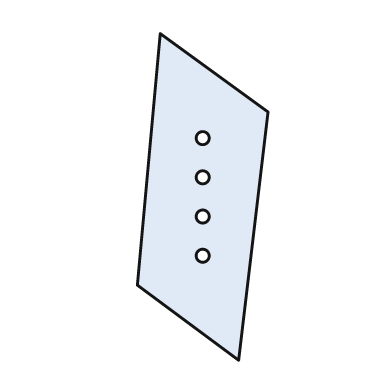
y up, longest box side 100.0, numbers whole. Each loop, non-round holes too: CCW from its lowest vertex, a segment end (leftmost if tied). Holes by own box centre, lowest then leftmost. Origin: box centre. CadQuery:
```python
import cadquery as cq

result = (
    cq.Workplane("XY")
    .moveTo(11.0, -50.0)
    .lineTo(20.0, 26.0)
    .lineTo(-13.0, 50.0)
    .lineTo(-20.0, -27.0)
    .close()
    .moveTo(0.0, -18.0)
    .circle(2.0)
    .moveTo(0.0, -6.0)
    .circle(2.0)
    .moveTo(0.0, 6.0)
    .circle(2.0)
    .moveTo(0.0, 18.0)
    .circle(2.0)
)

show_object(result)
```